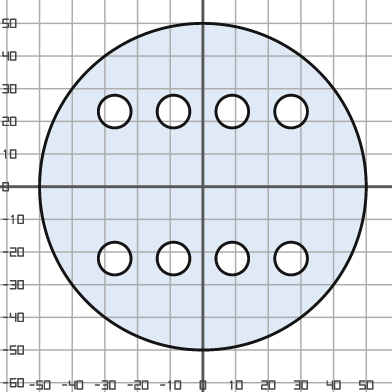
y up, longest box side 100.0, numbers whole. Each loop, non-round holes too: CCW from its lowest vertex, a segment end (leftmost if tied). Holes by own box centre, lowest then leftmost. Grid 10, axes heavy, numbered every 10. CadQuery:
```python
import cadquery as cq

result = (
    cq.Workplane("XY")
    .moveTo(0.0, 0.0)
    .circle(50.0)
    .moveTo(-27.0, -22.0)
    .circle(5.0)
    .moveTo(-9.0, -22.0)
    .circle(5.0)
    .moveTo(9.0, -22.0)
    .circle(5.0)
    .moveTo(27.0, -22.0)
    .circle(5.0)
    .moveTo(-27.0, 23.0)
    .circle(5.0)
    .moveTo(-9.0, 23.0)
    .circle(5.0)
    .moveTo(9.0, 23.0)
    .circle(5.0)
    .moveTo(27.0, 23.0)
    .circle(5.0)
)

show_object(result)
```